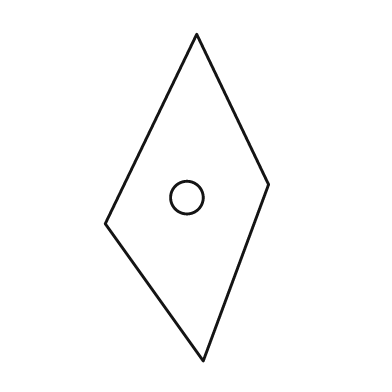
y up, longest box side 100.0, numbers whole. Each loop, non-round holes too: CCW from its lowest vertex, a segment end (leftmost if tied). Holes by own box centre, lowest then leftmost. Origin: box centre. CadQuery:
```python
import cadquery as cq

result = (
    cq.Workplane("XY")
    .moveTo(5.0, -50.0)
    .lineTo(25.0, 4.0)
    .lineTo(3.0, 50.0)
    .lineTo(-25.0, -8.0)
    .close()
    .moveTo(0.0, 0.0)
    .circle(5.0)
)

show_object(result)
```